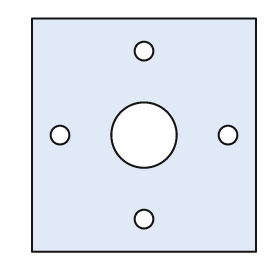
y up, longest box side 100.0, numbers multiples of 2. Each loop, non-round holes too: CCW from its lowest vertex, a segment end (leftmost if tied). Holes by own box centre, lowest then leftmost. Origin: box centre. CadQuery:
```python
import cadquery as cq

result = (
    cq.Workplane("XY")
    .moveTo(-48.0, -50.0)
    .lineTo(48.0, -50.0)
    .lineTo(48.0, 50.0)
    .lineTo(-48.0, 50.0)
    .close()
    .moveTo(0.0, -36.0)
    .circle(4.0)
    .moveTo(-36.0, 0.0)
    .circle(4.0)
    .moveTo(0.0, 0.0)
    .circle(14.0)
    .moveTo(36.0, 0.0)
    .circle(4.0)
    .moveTo(0.0, 36.0)
    .circle(4.0)
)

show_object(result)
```